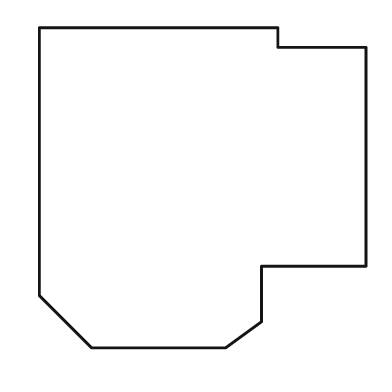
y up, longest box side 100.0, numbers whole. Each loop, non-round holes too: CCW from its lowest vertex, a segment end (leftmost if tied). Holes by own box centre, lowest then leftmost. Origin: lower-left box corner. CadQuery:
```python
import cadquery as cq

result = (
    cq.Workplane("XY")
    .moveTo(16.0, 0.0)
    .lineTo(57.0, 0.0)
    .lineTo(68.0, 8.0)
    .lineTo(68.0, 25.0)
    .lineTo(100.0, 25.0)
    .lineTo(100.0, 92.0)
    .lineTo(73.0, 92.0)
    .lineTo(73.0, 98.0)
    .lineTo(0.0, 98.0)
    .lineTo(0.0, 16.0)
    .close()
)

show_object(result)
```